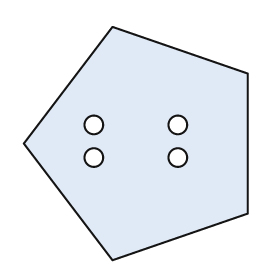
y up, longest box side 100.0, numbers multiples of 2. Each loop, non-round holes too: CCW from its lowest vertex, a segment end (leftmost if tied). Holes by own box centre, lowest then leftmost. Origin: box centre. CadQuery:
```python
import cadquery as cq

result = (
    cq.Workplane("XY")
    .moveTo(-10.0, -50.0)
    .lineTo(48.0, -30.0)
    .lineTo(48.0, 30.0)
    .lineTo(-10.0, 50.0)
    .lineTo(-48.0, 0.0)
    .close()
    .moveTo(-18.0, -6.0)
    .circle(4.0)
    .moveTo(18.0, -6.0)
    .circle(4.0)
    .moveTo(-18.0, 8.0)
    .circle(4.0)
    .moveTo(18.0, 8.0)
    .circle(4.0)
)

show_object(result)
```